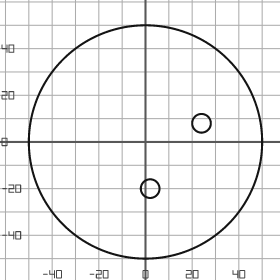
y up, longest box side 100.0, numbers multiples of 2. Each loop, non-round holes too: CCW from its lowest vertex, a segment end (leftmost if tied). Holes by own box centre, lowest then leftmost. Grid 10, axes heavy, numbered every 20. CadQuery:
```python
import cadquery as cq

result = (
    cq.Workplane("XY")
    .moveTo(0.0, 0.0)
    .circle(50.0)
    .moveTo(2.0, -20.0)
    .circle(4.0)
    .moveTo(24.0, 8.0)
    .circle(4.0)
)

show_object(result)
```